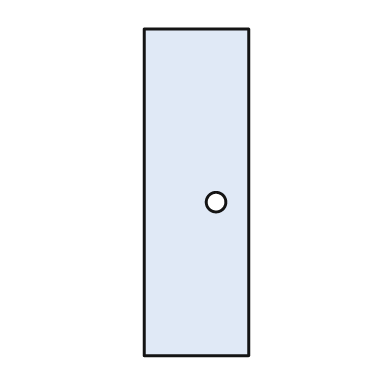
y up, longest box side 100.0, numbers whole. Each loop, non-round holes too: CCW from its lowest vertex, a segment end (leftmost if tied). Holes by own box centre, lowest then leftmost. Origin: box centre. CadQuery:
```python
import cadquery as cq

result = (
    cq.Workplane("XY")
    .moveTo(-16.0, -50.0)
    .lineTo(16.0, -50.0)
    .lineTo(16.0, 50.0)
    .lineTo(-16.0, 50.0)
    .close()
    .moveTo(6.0, -3.0)
    .circle(3.0)
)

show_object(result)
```